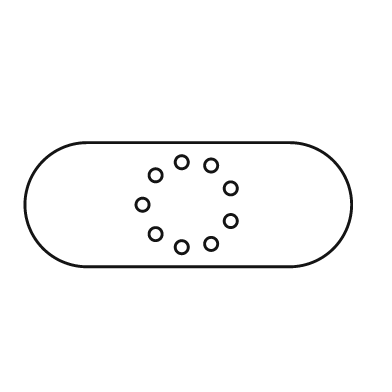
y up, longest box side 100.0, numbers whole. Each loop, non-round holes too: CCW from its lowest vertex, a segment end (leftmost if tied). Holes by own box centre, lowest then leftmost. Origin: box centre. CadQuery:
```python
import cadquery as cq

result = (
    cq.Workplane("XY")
    .moveTo(-31.0, -19.0)
    .lineTo(31.0, -19.0)
    .threePointArc((50.0, 0.0), (31.0, 19.0))
    .lineTo(-31.0, 19.0)
    .threePointArc((-50.0, 0.0), (-31.0, -19.0))
    .close()
    .moveTo(-2.0, -13.0)
    .circle(2.0)
    .moveTo(7.0, -12.0)
    .circle(2.0)
    .moveTo(-10.0, -9.0)
    .circle(2.0)
    .moveTo(13.0, -5.0)
    .circle(2.0)
    .moveTo(-14.0, 0.0)
    .circle(2.0)
    .moveTo(13.0, 5.0)
    .circle(2.0)
    .moveTo(-10.0, 9.0)
    .circle(2.0)
    .moveTo(7.0, 12.0)
    .circle(2.0)
    .moveTo(-2.0, 13.0)
    .circle(2.0)
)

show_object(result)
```